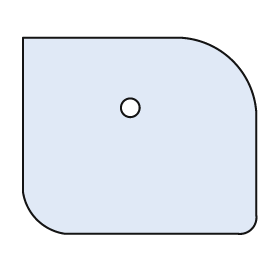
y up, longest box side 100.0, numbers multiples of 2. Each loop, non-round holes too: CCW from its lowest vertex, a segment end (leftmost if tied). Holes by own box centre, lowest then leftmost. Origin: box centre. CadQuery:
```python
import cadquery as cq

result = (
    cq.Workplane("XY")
    .moveTo(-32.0, -42.0)
    .lineTo(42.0, -42.0)
    .threePointArc((48.0, -40.0), (50.0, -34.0))
    .lineTo(50.0, 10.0)
    .threePointArc((40.0, 32.0), (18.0, 42.0))
    .lineTo(-50.0, 42.0)
    .lineTo(-50.0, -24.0)
    .threePointArc((-44.0, -36.0), (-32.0, -42.0))
    .close()
    .moveTo(-4.0, 12.0)
    .circle(4.0)
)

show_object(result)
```